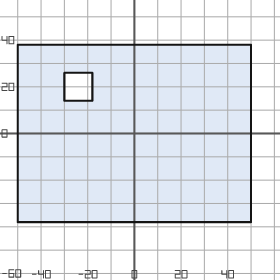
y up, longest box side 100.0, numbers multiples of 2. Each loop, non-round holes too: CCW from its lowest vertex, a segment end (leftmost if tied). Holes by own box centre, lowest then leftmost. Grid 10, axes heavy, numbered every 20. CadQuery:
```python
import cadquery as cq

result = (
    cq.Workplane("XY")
    .moveTo(-50.0, -38.0)
    .lineTo(50.0, -38.0)
    .lineTo(50.0, 38.0)
    .lineTo(-50.0, 38.0)
    .close()
    .moveTo(-30.0, 14.0)
    .lineTo(-18.0, 14.0)
    .lineTo(-18.0, 26.0)
    .lineTo(-30.0, 26.0)
    .close()
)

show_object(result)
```